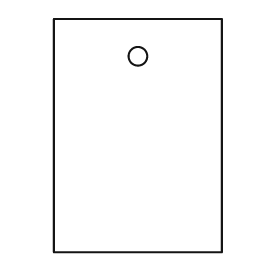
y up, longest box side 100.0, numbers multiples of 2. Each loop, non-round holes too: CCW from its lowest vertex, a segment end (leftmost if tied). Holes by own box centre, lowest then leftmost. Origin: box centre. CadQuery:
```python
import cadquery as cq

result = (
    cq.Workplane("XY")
    .moveTo(-36.0, -50.0)
    .lineTo(36.0, -50.0)
    .lineTo(36.0, 50.0)
    .lineTo(-36.0, 50.0)
    .close()
    .moveTo(0.0, 34.0)
    .circle(4.0)
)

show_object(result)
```